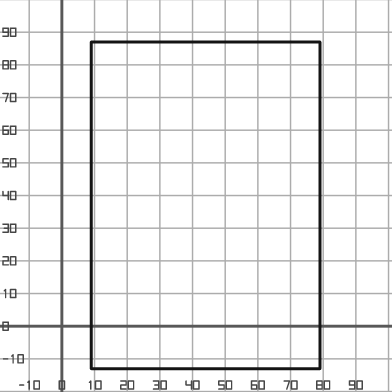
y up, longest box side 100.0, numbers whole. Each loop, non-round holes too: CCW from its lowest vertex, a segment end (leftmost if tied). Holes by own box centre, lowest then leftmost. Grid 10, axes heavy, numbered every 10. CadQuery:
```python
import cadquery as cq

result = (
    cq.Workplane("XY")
    .moveTo(9.0, -13.0)
    .lineTo(79.0, -13.0)
    .lineTo(79.0, 87.0)
    .lineTo(9.0, 87.0)
    .close()
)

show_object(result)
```